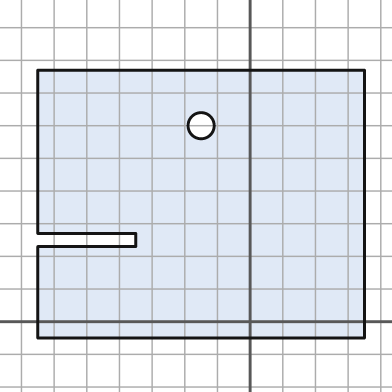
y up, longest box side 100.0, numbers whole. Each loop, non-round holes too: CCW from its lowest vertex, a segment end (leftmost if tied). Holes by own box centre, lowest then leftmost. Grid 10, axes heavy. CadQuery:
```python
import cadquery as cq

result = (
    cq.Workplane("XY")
    .moveTo(-65.0, -5.0)
    .lineTo(35.0, -5.0)
    .lineTo(35.0, 77.0)
    .lineTo(-65.0, 77.0)
    .lineTo(-65.0, 27.0)
    .lineTo(-35.0, 27.0)
    .lineTo(-35.0, 23.0)
    .lineTo(-65.0, 23.0)
    .close()
    .moveTo(-15.0, 60.0)
    .circle(4.0)
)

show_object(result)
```